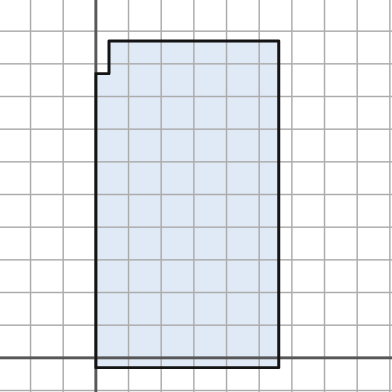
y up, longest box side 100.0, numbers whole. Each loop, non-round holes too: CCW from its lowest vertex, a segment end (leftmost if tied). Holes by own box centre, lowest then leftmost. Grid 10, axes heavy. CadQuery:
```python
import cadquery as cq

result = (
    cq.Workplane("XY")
    .moveTo(0.0, -3.0)
    .lineTo(56.0, -3.0)
    .lineTo(56.0, 97.0)
    .lineTo(4.0, 97.0)
    .lineTo(4.0, 87.0)
    .lineTo(0.0, 87.0)
    .close()
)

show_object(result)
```